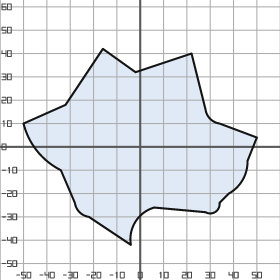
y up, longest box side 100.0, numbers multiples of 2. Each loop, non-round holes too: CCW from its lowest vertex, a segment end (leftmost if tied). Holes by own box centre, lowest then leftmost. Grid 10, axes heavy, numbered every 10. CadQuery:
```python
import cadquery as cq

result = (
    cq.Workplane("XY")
    .moveTo(-4.0, -42.0)
    .threePointArc((-2.0, -32.0), (6.0, -26.0))
    .lineTo(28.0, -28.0)
    .threePointArc((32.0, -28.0), (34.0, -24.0))
    .lineTo(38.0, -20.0)
    .threePointArc((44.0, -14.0), (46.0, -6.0))
    .lineTo(50.0, 4.0)
    .lineTo(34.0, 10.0)
    .threePointArc((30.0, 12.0), (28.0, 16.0))
    .lineTo(22.0, 40.0)
    .lineTo(-2.0, 32.0)
    .lineTo(-16.0, 42.0)
    .lineTo(-32.0, 18.0)
    .lineTo(-50.0, 10.0)
    .threePointArc((-44.0, -2.0), (-34.0, -10.0))
    .lineTo(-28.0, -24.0)
    .threePointArc((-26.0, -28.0), (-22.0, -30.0))
    .close()
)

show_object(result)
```